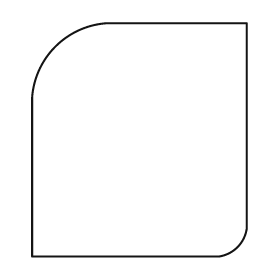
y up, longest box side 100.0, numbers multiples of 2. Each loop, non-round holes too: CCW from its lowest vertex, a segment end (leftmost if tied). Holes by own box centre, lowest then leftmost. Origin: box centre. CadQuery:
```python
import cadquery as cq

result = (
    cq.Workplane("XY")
    .moveTo(-46.0, -50.0)
    .lineTo(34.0, -50.0)
    .threePointArc((42.0, -46.0), (46.0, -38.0))
    .lineTo(46.0, 50.0)
    .lineTo(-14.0, 50.0)
    .threePointArc((-36.0, 40.0), (-46.0, 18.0))
    .close()
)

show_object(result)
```